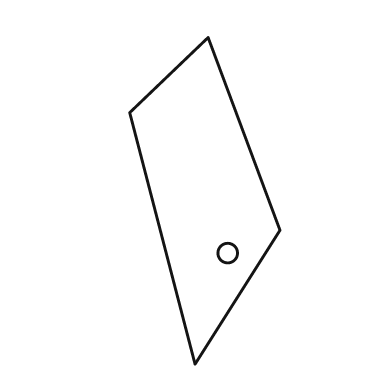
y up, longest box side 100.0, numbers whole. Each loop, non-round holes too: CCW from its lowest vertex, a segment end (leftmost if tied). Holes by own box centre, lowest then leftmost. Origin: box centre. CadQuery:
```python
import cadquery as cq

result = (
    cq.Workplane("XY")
    .moveTo(-3.0, -50.0)
    .lineTo(23.0, -9.0)
    .lineTo(1.0, 50.0)
    .lineTo(-23.0, 27.0)
    .close()
    .moveTo(7.0, -16.0)
    .circle(3.0)
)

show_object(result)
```